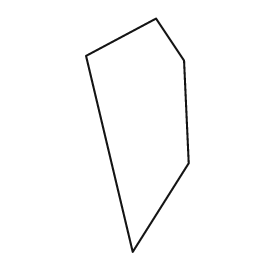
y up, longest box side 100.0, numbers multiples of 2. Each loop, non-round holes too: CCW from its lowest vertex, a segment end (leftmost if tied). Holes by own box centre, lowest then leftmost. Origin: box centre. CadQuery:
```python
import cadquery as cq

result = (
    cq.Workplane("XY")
    .moveTo(-2.0, -50.0)
    .lineTo(22.0, -12.0)
    .lineTo(20.0, 32.0)
    .lineTo(8.0, 50.0)
    .lineTo(-22.0, 34.0)
    .close()
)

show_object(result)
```